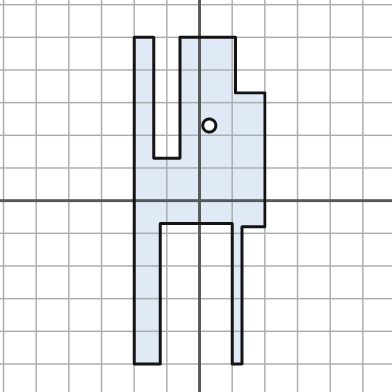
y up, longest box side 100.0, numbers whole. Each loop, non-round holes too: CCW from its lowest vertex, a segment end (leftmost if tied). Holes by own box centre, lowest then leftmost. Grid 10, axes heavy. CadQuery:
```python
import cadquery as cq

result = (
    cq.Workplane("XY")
    .moveTo(-20.0, -50.0)
    .lineTo(-12.0, -50.0)
    .lineTo(-12.0, -7.0)
    .lineTo(10.0, -7.0)
    .lineTo(10.0, -50.0)
    .lineTo(13.0, -50.0)
    .lineTo(13.0, -8.0)
    .lineTo(20.0, -8.0)
    .lineTo(20.0, 33.0)
    .lineTo(11.0, 33.0)
    .lineTo(11.0, 50.0)
    .lineTo(-6.0, 50.0)
    .lineTo(-6.0, 13.0)
    .lineTo(-14.0, 13.0)
    .lineTo(-14.0, 50.0)
    .lineTo(-20.0, 50.0)
    .close()
    .moveTo(3.0, 23.0)
    .circle(2.0)
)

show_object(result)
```